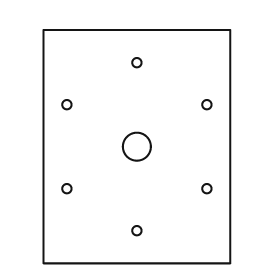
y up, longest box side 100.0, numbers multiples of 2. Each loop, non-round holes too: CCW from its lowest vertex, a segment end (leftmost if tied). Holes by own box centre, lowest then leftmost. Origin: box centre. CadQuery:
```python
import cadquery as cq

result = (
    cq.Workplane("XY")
    .moveTo(-40.0, -50.0)
    .lineTo(40.0, -50.0)
    .lineTo(40.0, 50.0)
    .lineTo(-40.0, 50.0)
    .close()
    .moveTo(0.0, -36.0)
    .circle(2.0)
    .moveTo(-30.0, -18.0)
    .circle(2.0)
    .moveTo(30.0, -18.0)
    .circle(2.0)
    .moveTo(0.0, 0.0)
    .circle(6.0)
    .moveTo(-30.0, 18.0)
    .circle(2.0)
    .moveTo(30.0, 18.0)
    .circle(2.0)
    .moveTo(0.0, 36.0)
    .circle(2.0)
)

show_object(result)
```